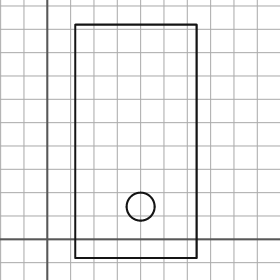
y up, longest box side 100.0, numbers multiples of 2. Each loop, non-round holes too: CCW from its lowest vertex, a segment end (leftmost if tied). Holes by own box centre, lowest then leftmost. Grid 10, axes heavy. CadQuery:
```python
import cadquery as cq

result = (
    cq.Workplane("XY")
    .moveTo(12.0, -8.0)
    .lineTo(64.0, -8.0)
    .lineTo(64.0, 92.0)
    .lineTo(12.0, 92.0)
    .close()
    .moveTo(40.0, 14.0)
    .circle(6.0)
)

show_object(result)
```